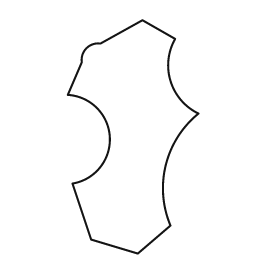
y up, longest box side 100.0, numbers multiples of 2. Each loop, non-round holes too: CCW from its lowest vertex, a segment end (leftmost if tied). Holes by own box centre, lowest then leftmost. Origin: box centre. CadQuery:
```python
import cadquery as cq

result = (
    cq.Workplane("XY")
    .moveTo(2.0, -50.0)
    .lineTo(16.0, -38.0)
    .threePointArc((14.0, -12.0), (28.0, 10.0))
    .threePointArc((16.0, 24.0), (18.0, 42.0))
    .lineTo(4.0, 50.0)
    .lineTo(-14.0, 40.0)
    .threePointArc((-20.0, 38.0), (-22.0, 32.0))
    .lineTo(-28.0, 18.0)
    .threePointArc((-10.0, 0.0), (-26.0, -20.0))
    .lineTo(-18.0, -44.0)
    .close()
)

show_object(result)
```